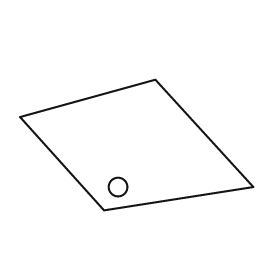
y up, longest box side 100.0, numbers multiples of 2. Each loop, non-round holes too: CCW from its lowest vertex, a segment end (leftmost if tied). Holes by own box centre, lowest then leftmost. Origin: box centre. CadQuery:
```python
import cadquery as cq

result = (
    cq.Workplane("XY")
    .moveTo(-14.0, -28.0)
    .lineTo(50.0, -18.0)
    .lineTo(8.0, 28.0)
    .lineTo(-50.0, 12.0)
    .close()
    .moveTo(-8.0, -18.0)
    .circle(4.0)
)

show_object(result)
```